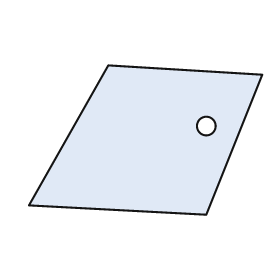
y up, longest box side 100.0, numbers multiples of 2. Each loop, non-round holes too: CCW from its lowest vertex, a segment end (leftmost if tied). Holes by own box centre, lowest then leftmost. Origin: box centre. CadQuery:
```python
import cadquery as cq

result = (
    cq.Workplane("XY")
    .moveTo(26.0, -32.0)
    .lineTo(50.0, 28.0)
    .lineTo(-16.0, 32.0)
    .lineTo(-50.0, -28.0)
    .close()
    .moveTo(26.0, 6.0)
    .circle(4.0)
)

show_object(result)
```